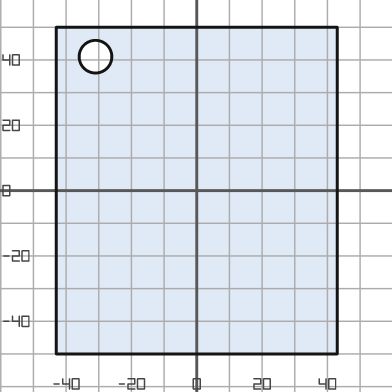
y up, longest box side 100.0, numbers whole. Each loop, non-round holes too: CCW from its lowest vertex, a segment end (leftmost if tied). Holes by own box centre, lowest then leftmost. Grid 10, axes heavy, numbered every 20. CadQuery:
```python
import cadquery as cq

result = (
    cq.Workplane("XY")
    .moveTo(-43.0, -50.0)
    .lineTo(43.0, -50.0)
    .lineTo(43.0, 50.0)
    .lineTo(-43.0, 50.0)
    .close()
    .moveTo(-31.0, 41.0)
    .circle(5.0)
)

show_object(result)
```